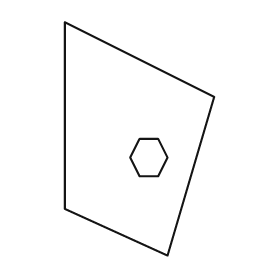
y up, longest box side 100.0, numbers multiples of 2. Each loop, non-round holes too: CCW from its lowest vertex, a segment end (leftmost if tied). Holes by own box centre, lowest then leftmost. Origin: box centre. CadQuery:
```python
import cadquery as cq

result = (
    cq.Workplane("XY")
    .moveTo(12.0, -50.0)
    .lineTo(32.0, 18.0)
    .lineTo(-32.0, 50.0)
    .lineTo(-32.0, -30.0)
    .close()
    .moveTo(0.0, -16.0)
    .lineTo(8.0, -16.0)
    .lineTo(12.0, -8.0)
    .lineTo(8.0, 0.0)
    .lineTo(0.0, 0.0)
    .lineTo(-4.0, -8.0)
    .close()
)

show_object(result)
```